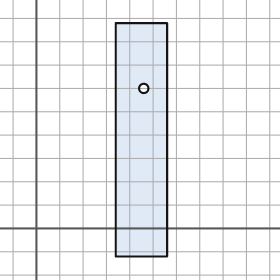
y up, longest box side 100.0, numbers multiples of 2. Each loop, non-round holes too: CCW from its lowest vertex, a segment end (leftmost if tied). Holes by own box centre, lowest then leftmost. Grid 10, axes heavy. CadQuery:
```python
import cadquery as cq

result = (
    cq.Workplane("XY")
    .moveTo(34.0, -12.0)
    .lineTo(56.0, -12.0)
    .lineTo(56.0, 88.0)
    .lineTo(34.0, 88.0)
    .close()
    .moveTo(46.0, 60.0)
    .circle(2.0)
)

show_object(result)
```